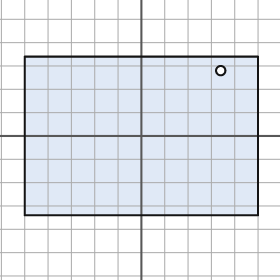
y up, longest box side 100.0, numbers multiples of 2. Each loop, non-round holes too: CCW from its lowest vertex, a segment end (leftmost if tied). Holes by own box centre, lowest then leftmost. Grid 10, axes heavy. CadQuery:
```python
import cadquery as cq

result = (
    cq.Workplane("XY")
    .moveTo(-50.0, -34.0)
    .lineTo(50.0, -34.0)
    .lineTo(50.0, 34.0)
    .lineTo(-50.0, 34.0)
    .close()
    .moveTo(34.0, 28.0)
    .circle(2.0)
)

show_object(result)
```